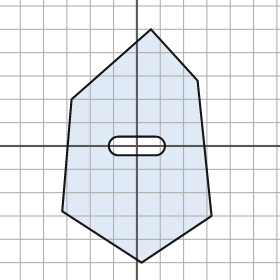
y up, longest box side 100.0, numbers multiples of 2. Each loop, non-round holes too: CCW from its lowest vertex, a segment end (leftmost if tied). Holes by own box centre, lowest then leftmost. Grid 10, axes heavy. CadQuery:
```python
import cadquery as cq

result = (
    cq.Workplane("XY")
    .moveTo(2.0, -50.0)
    .lineTo(32.0, -30.0)
    .lineTo(26.0, 28.0)
    .lineTo(6.0, 50.0)
    .lineTo(-28.0, 20.0)
    .lineTo(-32.0, -28.0)
    .close()
    .moveTo(-8.0, -4.0)
    .lineTo(8.0, -4.0)
    .threePointArc((12.0, 0.0), (8.0, 4.0))
    .lineTo(-8.0, 4.0)
    .threePointArc((-12.0, 0.0), (-8.0, -4.0))
    .close()
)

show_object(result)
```